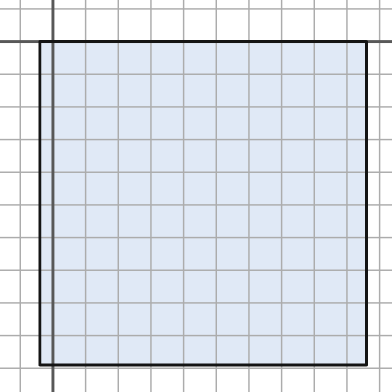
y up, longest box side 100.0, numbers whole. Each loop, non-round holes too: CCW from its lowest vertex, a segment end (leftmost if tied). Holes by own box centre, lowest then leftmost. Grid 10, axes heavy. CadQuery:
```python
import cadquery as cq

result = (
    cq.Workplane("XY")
    .moveTo(-4.0, -99.0)
    .lineTo(96.0, -99.0)
    .lineTo(96.0, 0.0)
    .lineTo(-4.0, 0.0)
    .close()
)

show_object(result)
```